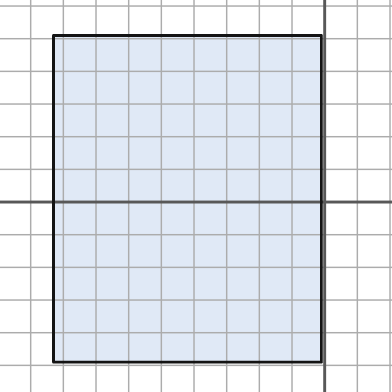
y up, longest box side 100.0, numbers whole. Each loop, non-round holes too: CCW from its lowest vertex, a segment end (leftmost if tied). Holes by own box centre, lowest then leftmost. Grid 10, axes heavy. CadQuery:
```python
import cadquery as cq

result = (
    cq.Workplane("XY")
    .moveTo(-83.0, -49.0)
    .lineTo(-1.0, -49.0)
    .lineTo(-1.0, 51.0)
    .lineTo(-83.0, 51.0)
    .close()
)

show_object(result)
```